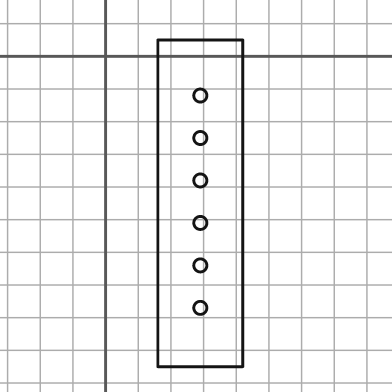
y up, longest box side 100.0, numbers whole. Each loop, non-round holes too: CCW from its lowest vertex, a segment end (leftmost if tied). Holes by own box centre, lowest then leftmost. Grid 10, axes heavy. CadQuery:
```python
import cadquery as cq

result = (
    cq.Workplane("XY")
    .moveTo(16.0, -95.0)
    .lineTo(42.0, -95.0)
    .lineTo(42.0, 5.0)
    .lineTo(16.0, 5.0)
    .close()
    .moveTo(29.0, -77.0)
    .circle(2.0)
    .moveTo(29.0, -64.0)
    .circle(2.0)
    .moveTo(29.0, -51.0)
    .circle(2.0)
    .moveTo(29.0, -38.0)
    .circle(2.0)
    .moveTo(29.0, -25.0)
    .circle(2.0)
    .moveTo(29.0, -12.0)
    .circle(2.0)
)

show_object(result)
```